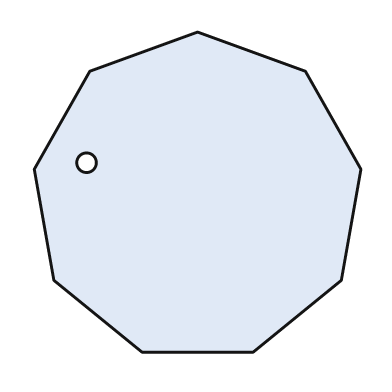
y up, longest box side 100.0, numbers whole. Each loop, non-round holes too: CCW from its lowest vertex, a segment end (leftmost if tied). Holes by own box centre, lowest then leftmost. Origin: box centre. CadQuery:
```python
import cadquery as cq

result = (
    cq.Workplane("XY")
    .moveTo(-17.0, -49.0)
    .lineTo(17.0, -49.0)
    .lineTo(44.0, -27.0)
    .lineTo(50.0, 7.0)
    .lineTo(33.0, 37.0)
    .lineTo(0.0, 49.0)
    .lineTo(-33.0, 37.0)
    .lineTo(-50.0, 7.0)
    .lineTo(-44.0, -27.0)
    .close()
    .moveTo(-34.0, 9.0)
    .circle(3.0)
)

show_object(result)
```